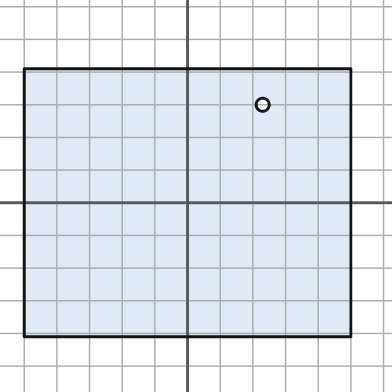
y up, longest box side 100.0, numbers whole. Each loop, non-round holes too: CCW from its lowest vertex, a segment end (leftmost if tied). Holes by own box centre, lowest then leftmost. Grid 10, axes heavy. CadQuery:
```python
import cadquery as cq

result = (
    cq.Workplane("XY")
    .moveTo(-50.0, -41.0)
    .lineTo(50.0, -41.0)
    .lineTo(50.0, 41.0)
    .lineTo(-50.0, 41.0)
    .close()
    .moveTo(23.0, 30.0)
    .circle(2.0)
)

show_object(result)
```